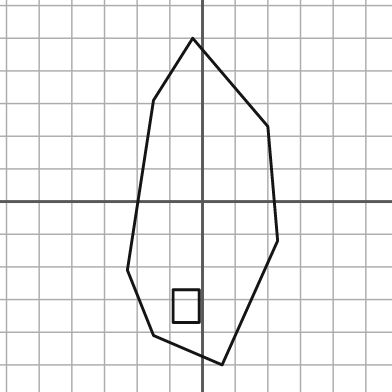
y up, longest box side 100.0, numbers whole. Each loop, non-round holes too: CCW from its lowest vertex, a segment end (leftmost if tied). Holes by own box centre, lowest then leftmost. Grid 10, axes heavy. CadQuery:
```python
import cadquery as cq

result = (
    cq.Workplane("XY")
    .moveTo(6.0, -50.0)
    .lineTo(23.0, -12.0)
    .lineTo(20.0, 23.0)
    .lineTo(-3.0, 50.0)
    .lineTo(-15.0, 31.0)
    .lineTo(-23.0, -21.0)
    .lineTo(-15.0, -41.0)
    .close()
    .moveTo(-9.0, -37.0)
    .lineTo(-1.0, -37.0)
    .lineTo(-1.0, -27.0)
    .lineTo(-9.0, -27.0)
    .close()
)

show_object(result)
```